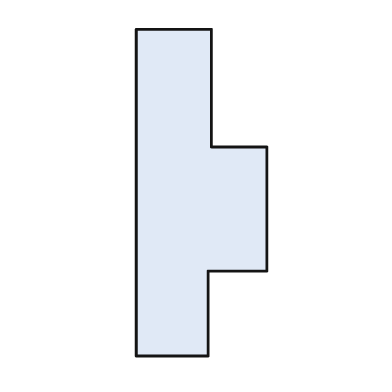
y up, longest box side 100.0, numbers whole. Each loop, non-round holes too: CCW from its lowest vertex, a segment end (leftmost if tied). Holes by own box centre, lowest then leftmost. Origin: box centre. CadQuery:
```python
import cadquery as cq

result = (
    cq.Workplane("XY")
    .moveTo(-20.0, -50.0)
    .lineTo(2.0, -50.0)
    .lineTo(2.0, -24.0)
    .lineTo(20.0, -24.0)
    .lineTo(20.0, 14.0)
    .lineTo(3.0, 14.0)
    .lineTo(3.0, 50.0)
    .lineTo(-20.0, 50.0)
    .close()
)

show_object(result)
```